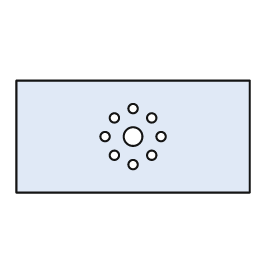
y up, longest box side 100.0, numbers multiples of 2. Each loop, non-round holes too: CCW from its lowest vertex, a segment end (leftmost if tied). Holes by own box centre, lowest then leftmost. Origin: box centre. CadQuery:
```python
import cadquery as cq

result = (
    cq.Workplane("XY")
    .moveTo(-50.0, -24.0)
    .lineTo(50.0, -24.0)
    .lineTo(50.0, 24.0)
    .lineTo(-50.0, 24.0)
    .close()
    .moveTo(0.0, -12.0)
    .circle(2.0)
    .moveTo(-8.0, -8.0)
    .circle(2.0)
    .moveTo(8.0, -8.0)
    .circle(2.0)
    .moveTo(-12.0, 0.0)
    .circle(2.0)
    .moveTo(0.0, 0.0)
    .circle(4.0)
    .moveTo(12.0, 0.0)
    .circle(2.0)
    .moveTo(-8.0, 8.0)
    .circle(2.0)
    .moveTo(8.0, 8.0)
    .circle(2.0)
    .moveTo(0.0, 12.0)
    .circle(2.0)
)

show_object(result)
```